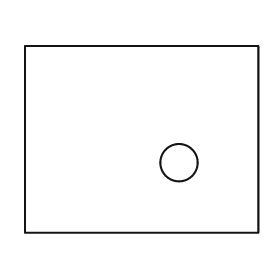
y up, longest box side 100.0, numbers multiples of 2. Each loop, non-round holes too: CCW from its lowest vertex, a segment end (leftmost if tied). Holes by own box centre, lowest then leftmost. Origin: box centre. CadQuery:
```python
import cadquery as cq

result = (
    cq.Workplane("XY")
    .moveTo(-50.0, -40.0)
    .lineTo(50.0, -40.0)
    .lineTo(50.0, 40.0)
    .lineTo(-50.0, 40.0)
    .close()
    .moveTo(16.0, -10.0)
    .circle(8.0)
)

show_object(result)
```